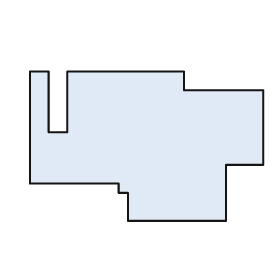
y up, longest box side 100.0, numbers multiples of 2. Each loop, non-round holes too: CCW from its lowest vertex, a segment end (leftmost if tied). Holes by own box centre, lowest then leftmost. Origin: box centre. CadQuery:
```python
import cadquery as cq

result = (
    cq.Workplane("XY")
    .moveTo(-8.0, -32.0)
    .lineTo(34.0, -32.0)
    .lineTo(34.0, -8.0)
    .lineTo(50.0, -8.0)
    .lineTo(50.0, 24.0)
    .lineTo(16.0, 24.0)
    .lineTo(16.0, 32.0)
    .lineTo(-34.0, 32.0)
    .lineTo(-34.0, 6.0)
    .lineTo(-42.0, 6.0)
    .lineTo(-42.0, 32.0)
    .lineTo(-50.0, 32.0)
    .lineTo(-50.0, -16.0)
    .lineTo(-12.0, -16.0)
    .lineTo(-12.0, -20.0)
    .lineTo(-8.0, -20.0)
    .close()
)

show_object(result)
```